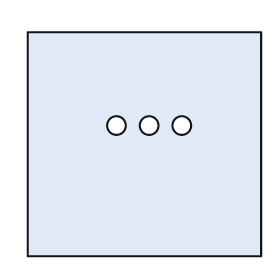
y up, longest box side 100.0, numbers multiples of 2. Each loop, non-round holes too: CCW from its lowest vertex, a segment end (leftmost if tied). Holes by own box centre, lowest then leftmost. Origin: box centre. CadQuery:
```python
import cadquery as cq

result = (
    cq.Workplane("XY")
    .moveTo(-50.0, -48.0)
    .lineTo(50.0, -48.0)
    .lineTo(50.0, 48.0)
    .lineTo(-50.0, 48.0)
    .close()
    .moveTo(-12.0, 8.0)
    .circle(4.0)
    .moveTo(2.0, 8.0)
    .circle(4.0)
    .moveTo(16.0, 8.0)
    .circle(4.0)
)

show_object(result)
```